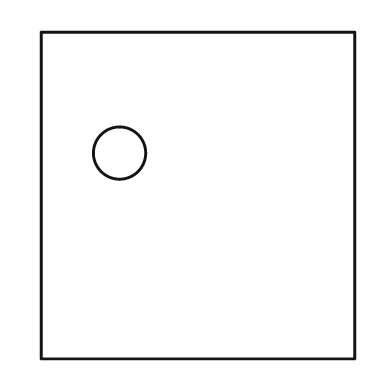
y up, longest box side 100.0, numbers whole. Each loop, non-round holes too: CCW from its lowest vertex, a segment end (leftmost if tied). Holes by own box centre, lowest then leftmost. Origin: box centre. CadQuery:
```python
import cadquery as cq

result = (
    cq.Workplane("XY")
    .moveTo(-48.0, -50.0)
    .lineTo(48.0, -50.0)
    .lineTo(48.0, 50.0)
    .lineTo(-48.0, 50.0)
    .close()
    .moveTo(-24.0, 13.0)
    .circle(8.0)
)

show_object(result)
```